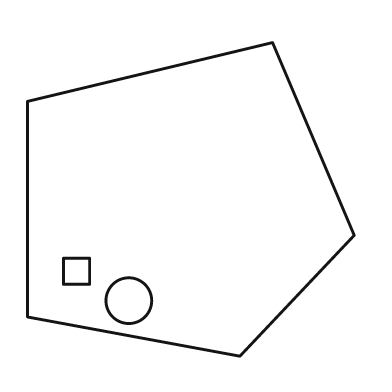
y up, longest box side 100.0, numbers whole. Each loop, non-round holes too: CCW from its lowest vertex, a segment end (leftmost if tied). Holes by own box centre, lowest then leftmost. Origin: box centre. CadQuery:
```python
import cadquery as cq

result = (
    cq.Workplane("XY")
    .moveTo(15.0, -48.0)
    .lineTo(50.0, -11.0)
    .lineTo(25.0, 48.0)
    .lineTo(-50.0, 30.0)
    .lineTo(-50.0, -36.0)
    .close()
    .moveTo(-19.0, -31.0)
    .circle(7.0)
    .moveTo(-39.0, -26.0)
    .lineTo(-31.0, -26.0)
    .lineTo(-31.0, -18.0)
    .lineTo(-39.0, -18.0)
    .close()
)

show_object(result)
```